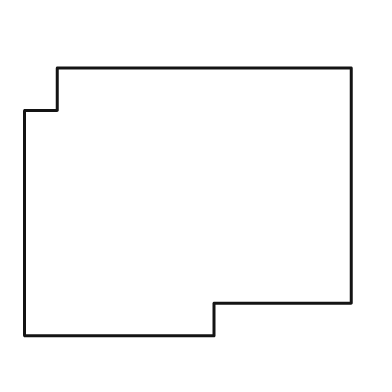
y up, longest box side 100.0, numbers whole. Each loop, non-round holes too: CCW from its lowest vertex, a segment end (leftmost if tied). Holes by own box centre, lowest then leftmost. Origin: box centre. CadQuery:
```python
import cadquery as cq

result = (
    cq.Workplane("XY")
    .moveTo(-50.0, -41.0)
    .lineTo(8.0, -41.0)
    .lineTo(8.0, -31.0)
    .lineTo(50.0, -31.0)
    .lineTo(50.0, 41.0)
    .lineTo(-40.0, 41.0)
    .lineTo(-40.0, 28.0)
    .lineTo(-50.0, 28.0)
    .close()
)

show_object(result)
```